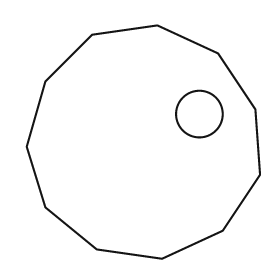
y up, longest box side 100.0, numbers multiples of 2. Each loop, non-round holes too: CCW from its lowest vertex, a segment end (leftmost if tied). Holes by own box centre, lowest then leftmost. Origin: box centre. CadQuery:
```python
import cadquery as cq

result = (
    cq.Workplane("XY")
    .moveTo(8.0, -50.0)
    .lineTo(34.0, -38.0)
    .lineTo(50.0, -14.0)
    .lineTo(48.0, 14.0)
    .lineTo(32.0, 38.0)
    .lineTo(6.0, 50.0)
    .lineTo(-22.0, 46.0)
    .lineTo(-42.0, 26.0)
    .lineTo(-50.0, -2.0)
    .lineTo(-42.0, -28.0)
    .lineTo(-20.0, -46.0)
    .close()
    .moveTo(24.0, 12.0)
    .circle(10.0)
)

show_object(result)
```